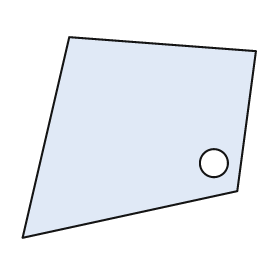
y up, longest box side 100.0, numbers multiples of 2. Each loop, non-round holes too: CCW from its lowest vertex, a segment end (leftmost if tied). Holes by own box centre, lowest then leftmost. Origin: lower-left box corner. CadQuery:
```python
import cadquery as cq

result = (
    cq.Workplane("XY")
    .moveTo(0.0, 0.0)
    .lineTo(92.0, 20.0)
    .lineTo(100.0, 80.0)
    .lineTo(20.0, 86.0)
    .close()
    .moveTo(82.0, 32.0)
    .circle(6.0)
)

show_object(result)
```